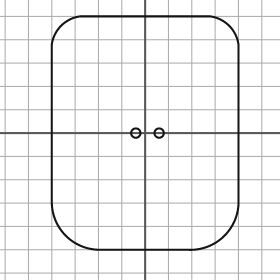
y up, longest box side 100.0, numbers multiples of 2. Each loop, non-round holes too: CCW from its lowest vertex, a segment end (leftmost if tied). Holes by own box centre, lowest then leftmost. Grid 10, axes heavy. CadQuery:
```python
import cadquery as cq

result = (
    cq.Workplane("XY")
    .moveTo(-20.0, -50.0)
    .lineTo(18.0, -50.0)
    .threePointArc((34.0, -44.0), (40.0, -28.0))
    .lineTo(40.0, 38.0)
    .threePointArc((36.0, 46.0), (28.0, 50.0))
    .lineTo(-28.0, 50.0)
    .threePointArc((-36.0, 46.0), (-40.0, 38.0))
    .lineTo(-40.0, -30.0)
    .threePointArc((-34.0, -44.0), (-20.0, -50.0))
    .close()
    .moveTo(-4.0, 0.0)
    .circle(2.0)
    .moveTo(6.0, 0.0)
    .circle(2.0)
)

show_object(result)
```